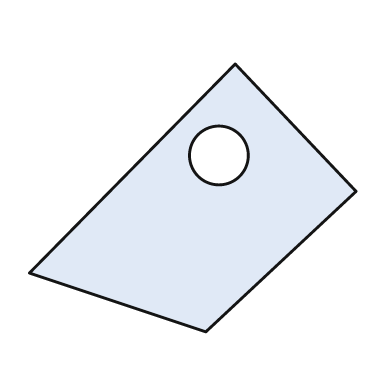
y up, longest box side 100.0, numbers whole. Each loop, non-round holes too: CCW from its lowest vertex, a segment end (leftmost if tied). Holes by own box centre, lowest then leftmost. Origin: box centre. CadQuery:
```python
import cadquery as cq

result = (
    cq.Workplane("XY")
    .moveTo(4.0, -41.0)
    .lineTo(50.0, 2.0)
    .lineTo(13.0, 41.0)
    .lineTo(-50.0, -23.0)
    .close()
    .moveTo(8.0, 13.0)
    .circle(9.0)
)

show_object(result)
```